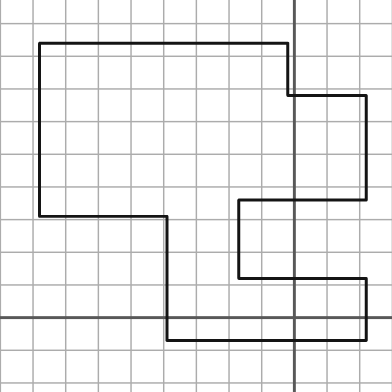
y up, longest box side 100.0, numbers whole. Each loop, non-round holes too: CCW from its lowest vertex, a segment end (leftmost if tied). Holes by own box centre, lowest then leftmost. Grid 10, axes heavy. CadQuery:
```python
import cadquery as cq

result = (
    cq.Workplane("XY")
    .moveTo(-39.0, -7.0)
    .lineTo(22.0, -7.0)
    .lineTo(22.0, 12.0)
    .lineTo(-17.0, 12.0)
    .lineTo(-17.0, 36.0)
    .lineTo(22.0, 36.0)
    .lineTo(22.0, 68.0)
    .lineTo(-2.0, 68.0)
    .lineTo(-2.0, 84.0)
    .lineTo(-78.0, 84.0)
    .lineTo(-78.0, 31.0)
    .lineTo(-39.0, 31.0)
    .close()
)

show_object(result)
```